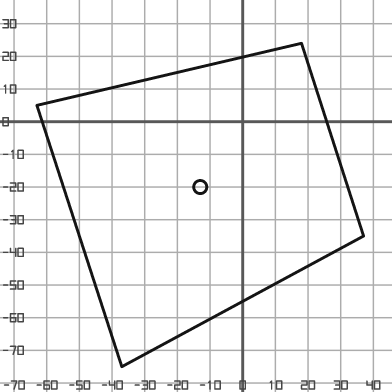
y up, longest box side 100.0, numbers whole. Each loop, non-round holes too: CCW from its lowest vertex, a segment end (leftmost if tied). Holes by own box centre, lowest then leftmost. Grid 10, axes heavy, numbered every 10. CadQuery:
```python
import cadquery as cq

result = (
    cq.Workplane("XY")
    .moveTo(-37.0, -75.0)
    .lineTo(37.0, -35.0)
    .lineTo(18.0, 24.0)
    .lineTo(-63.0, 5.0)
    .close()
    .moveTo(-13.0, -20.0)
    .circle(2.0)
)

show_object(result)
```